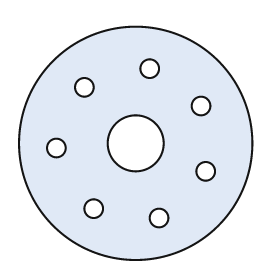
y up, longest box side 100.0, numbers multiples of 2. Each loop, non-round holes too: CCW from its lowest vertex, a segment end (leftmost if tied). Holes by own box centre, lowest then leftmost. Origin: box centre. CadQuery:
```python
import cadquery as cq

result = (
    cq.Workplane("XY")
    .moveTo(0.0, 0.0)
    .circle(50.0)
    .moveTo(10.0, -32.0)
    .circle(4.0)
    .moveTo(-18.0, -28.0)
    .circle(4.0)
    .moveTo(30.0, -12.0)
    .circle(4.0)
    .moveTo(-34.0, -2.0)
    .circle(4.0)
    .moveTo(0.0, 0.0)
    .circle(12.0)
    .moveTo(28.0, 16.0)
    .circle(4.0)
    .moveTo(-22.0, 24.0)
    .circle(4.0)
    .moveTo(6.0, 32.0)
    .circle(4.0)
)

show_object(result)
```